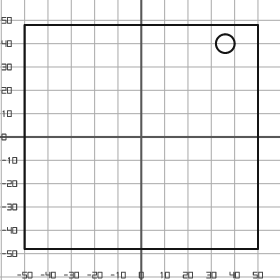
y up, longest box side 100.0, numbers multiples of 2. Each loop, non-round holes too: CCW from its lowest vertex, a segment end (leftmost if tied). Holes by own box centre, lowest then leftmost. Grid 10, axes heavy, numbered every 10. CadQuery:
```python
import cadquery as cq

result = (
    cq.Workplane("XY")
    .moveTo(-50.0, -48.0)
    .lineTo(50.0, -48.0)
    .lineTo(50.0, 48.0)
    .lineTo(-50.0, 48.0)
    .close()
    .moveTo(36.0, 40.0)
    .circle(4.0)
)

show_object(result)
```